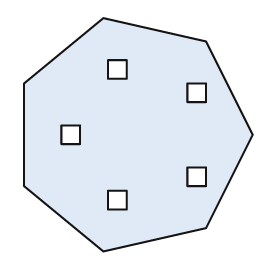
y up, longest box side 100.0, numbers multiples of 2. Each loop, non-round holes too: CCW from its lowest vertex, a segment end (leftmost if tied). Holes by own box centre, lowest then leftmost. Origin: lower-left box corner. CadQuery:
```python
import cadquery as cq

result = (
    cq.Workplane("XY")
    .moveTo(34.0, 0.0)
    .lineTo(78.0, 10.0)
    .lineTo(98.0, 50.0)
    .lineTo(78.0, 90.0)
    .lineTo(34.0, 100.0)
    .lineTo(0.0, 72.0)
    .lineTo(0.0, 28.0)
    .close()
    .moveTo(36.0, 18.0)
    .lineTo(44.0, 18.0)
    .lineTo(44.0, 26.0)
    .lineTo(36.0, 26.0)
    .close()
    .moveTo(70.0, 28.0)
    .lineTo(78.0, 28.0)
    .lineTo(78.0, 36.0)
    .lineTo(70.0, 36.0)
    .close()
    .moveTo(16.0, 46.0)
    .lineTo(24.0, 46.0)
    .lineTo(24.0, 54.0)
    .lineTo(16.0, 54.0)
    .close()
    .moveTo(70.0, 64.0)
    .lineTo(78.0, 64.0)
    .lineTo(78.0, 72.0)
    .lineTo(70.0, 72.0)
    .close()
    .moveTo(36.0, 74.0)
    .lineTo(44.0, 74.0)
    .lineTo(44.0, 82.0)
    .lineTo(36.0, 82.0)
    .close()
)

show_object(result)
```